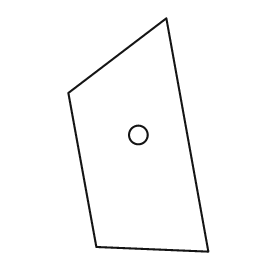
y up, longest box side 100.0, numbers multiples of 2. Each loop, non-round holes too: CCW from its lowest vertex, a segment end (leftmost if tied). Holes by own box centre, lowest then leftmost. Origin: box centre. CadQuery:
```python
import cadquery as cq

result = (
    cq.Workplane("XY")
    .moveTo(30.0, -50.0)
    .lineTo(12.0, 50.0)
    .lineTo(-30.0, 18.0)
    .lineTo(-18.0, -48.0)
    .close()
    .moveTo(0.0, 0.0)
    .circle(4.0)
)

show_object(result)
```